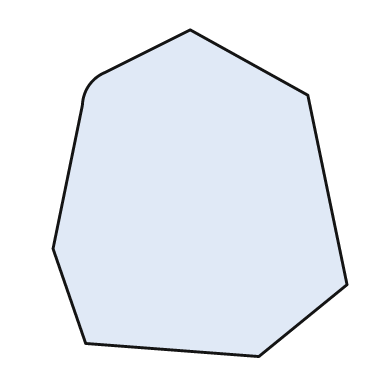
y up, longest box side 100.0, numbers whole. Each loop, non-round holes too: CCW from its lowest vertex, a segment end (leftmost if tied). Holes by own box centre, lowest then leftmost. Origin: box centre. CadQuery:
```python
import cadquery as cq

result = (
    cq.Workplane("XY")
    .moveTo(18.0, -50.0)
    .lineTo(45.0, -28.0)
    .lineTo(33.0, 30.0)
    .lineTo(-3.0, 50.0)
    .lineTo(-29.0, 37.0)
    .threePointArc((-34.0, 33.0), (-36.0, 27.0))
    .lineTo(-45.0, -17.0)
    .lineTo(-35.0, -46.0)
    .close()
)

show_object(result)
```